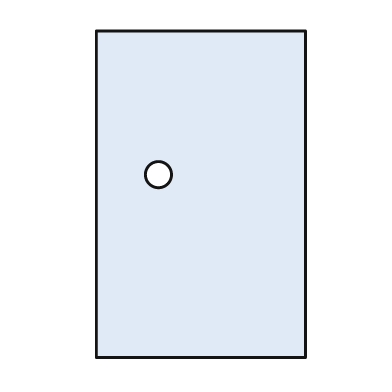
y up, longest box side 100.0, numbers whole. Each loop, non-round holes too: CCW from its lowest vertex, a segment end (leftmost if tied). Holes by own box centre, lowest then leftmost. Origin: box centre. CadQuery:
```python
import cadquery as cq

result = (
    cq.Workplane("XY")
    .moveTo(-32.0, -50.0)
    .lineTo(32.0, -50.0)
    .lineTo(32.0, 50.0)
    .lineTo(-32.0, 50.0)
    .close()
    .moveTo(-13.0, 6.0)
    .circle(4.0)
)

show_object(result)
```